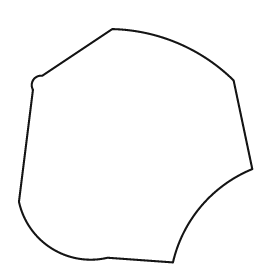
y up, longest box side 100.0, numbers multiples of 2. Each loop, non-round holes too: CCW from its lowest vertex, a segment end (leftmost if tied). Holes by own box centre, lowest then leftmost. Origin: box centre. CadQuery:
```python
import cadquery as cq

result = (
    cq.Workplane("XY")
    .moveTo(16.0, -50.0)
    .threePointArc((28.0, -26.0), (50.0, -10.0))
    .lineTo(42.0, 28.0)
    .threePointArc((18.0, 44.0), (-10.0, 50.0))
    .lineTo(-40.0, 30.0)
    .threePointArc((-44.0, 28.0), (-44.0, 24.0))
    .lineTo(-50.0, -24.0)
    .threePointArc((-36.0, -44.0), (-12.0, -48.0))
    .close()
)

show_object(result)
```